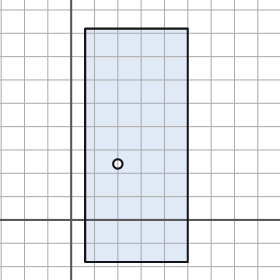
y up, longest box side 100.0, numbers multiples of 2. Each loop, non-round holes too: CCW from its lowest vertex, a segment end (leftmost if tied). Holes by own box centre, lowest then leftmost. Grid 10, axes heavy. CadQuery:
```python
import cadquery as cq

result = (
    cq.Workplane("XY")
    .moveTo(6.0, -18.0)
    .lineTo(50.0, -18.0)
    .lineTo(50.0, 82.0)
    .lineTo(6.0, 82.0)
    .close()
    .moveTo(20.0, 24.0)
    .circle(2.0)
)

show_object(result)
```